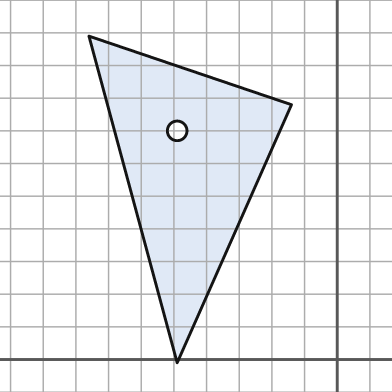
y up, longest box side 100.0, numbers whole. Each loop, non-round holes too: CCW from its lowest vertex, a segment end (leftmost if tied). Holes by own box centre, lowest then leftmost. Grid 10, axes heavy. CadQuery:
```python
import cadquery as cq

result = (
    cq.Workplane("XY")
    .moveTo(-49.0, -1.0)
    .lineTo(-14.0, 78.0)
    .lineTo(-76.0, 99.0)
    .close()
    .moveTo(-49.0, 70.0)
    .circle(3.0)
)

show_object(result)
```